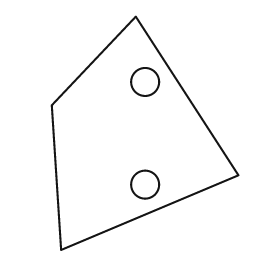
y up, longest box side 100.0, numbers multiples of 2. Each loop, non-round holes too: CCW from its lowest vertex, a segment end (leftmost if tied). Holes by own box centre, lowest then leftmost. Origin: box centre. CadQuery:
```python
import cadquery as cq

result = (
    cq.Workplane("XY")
    .moveTo(-36.0, -50.0)
    .lineTo(40.0, -18.0)
    .lineTo(-4.0, 50.0)
    .lineTo(-40.0, 12.0)
    .close()
    .moveTo(0.0, -22.0)
    .circle(6.0)
    .moveTo(0.0, 22.0)
    .circle(6.0)
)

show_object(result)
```